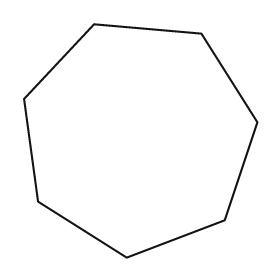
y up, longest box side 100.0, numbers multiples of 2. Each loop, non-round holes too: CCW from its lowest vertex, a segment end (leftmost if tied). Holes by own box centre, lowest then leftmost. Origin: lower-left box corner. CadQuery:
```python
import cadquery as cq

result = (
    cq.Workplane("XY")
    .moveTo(44.0, 0.0)
    .lineTo(86.0, 16.0)
    .lineTo(100.0, 58.0)
    .lineTo(76.0, 96.0)
    .lineTo(30.0, 100.0)
    .lineTo(0.0, 68.0)
    .lineTo(6.0, 24.0)
    .close()
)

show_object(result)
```